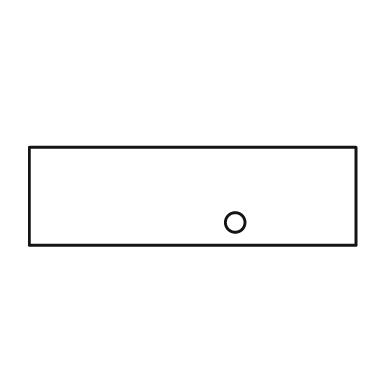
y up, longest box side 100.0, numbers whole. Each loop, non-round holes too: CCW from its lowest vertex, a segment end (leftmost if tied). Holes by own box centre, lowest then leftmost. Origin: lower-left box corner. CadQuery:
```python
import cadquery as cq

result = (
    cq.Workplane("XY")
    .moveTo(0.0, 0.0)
    .lineTo(100.0, 0.0)
    .lineTo(100.0, 30.0)
    .lineTo(0.0, 30.0)
    .close()
    .moveTo(63.0, 7.0)
    .circle(3.0)
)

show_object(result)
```